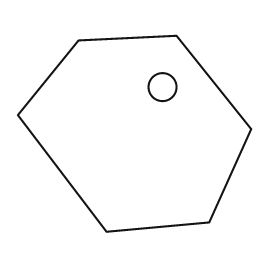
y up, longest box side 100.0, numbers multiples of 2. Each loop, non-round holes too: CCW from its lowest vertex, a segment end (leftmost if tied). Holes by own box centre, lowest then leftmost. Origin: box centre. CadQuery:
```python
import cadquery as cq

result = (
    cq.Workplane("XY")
    .moveTo(-12.0, -42.0)
    .lineTo(32.0, -38.0)
    .lineTo(50.0, 2.0)
    .lineTo(18.0, 42.0)
    .lineTo(-24.0, 40.0)
    .lineTo(-50.0, 8.0)
    .close()
    .moveTo(12.0, 20.0)
    .circle(6.0)
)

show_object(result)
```